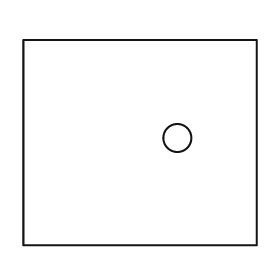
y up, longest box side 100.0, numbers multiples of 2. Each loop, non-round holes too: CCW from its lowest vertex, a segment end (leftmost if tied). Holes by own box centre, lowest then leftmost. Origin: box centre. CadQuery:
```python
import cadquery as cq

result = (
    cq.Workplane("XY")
    .moveTo(-50.0, -44.0)
    .lineTo(50.0, -44.0)
    .lineTo(50.0, 44.0)
    .lineTo(-50.0, 44.0)
    .close()
    .moveTo(16.0, 2.0)
    .circle(6.0)
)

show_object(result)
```